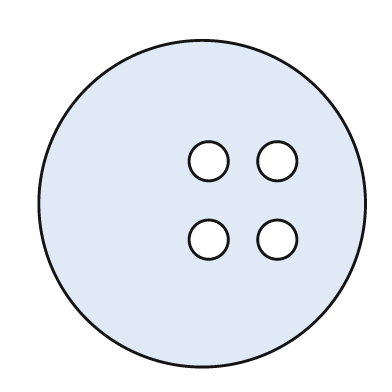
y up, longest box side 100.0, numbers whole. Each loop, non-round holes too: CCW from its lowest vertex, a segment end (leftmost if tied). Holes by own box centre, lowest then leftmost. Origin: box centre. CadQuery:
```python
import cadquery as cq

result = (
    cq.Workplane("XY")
    .moveTo(0.0, 0.0)
    .circle(50.0)
    .moveTo(2.0, -11.0)
    .circle(6.0)
    .moveTo(23.0, -11.0)
    .circle(6.0)
    .moveTo(2.0, 13.0)
    .circle(6.0)
    .moveTo(23.0, 13.0)
    .circle(6.0)
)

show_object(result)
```